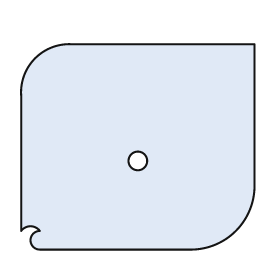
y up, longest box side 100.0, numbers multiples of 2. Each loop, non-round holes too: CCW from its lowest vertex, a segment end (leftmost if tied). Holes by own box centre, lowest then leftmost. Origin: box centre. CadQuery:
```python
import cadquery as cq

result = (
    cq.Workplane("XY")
    .moveTo(-42.0, -44.0)
    .lineTo(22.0, -44.0)
    .threePointArc((42.0, -36.0), (50.0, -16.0))
    .lineTo(50.0, 44.0)
    .lineTo(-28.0, 44.0)
    .threePointArc((-44.0, 38.0), (-50.0, 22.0))
    .lineTo(-50.0, -36.0)
    .threePointArc((-46.0, -34.0), (-42.0, -36.0))
    .threePointArc((-46.0, -40.0), (-42.0, -44.0))
    .close()
    .moveTo(0.0, -6.0)
    .circle(4.0)
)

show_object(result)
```